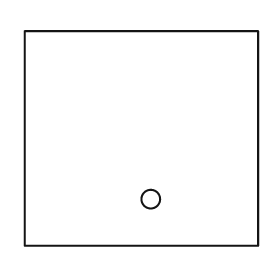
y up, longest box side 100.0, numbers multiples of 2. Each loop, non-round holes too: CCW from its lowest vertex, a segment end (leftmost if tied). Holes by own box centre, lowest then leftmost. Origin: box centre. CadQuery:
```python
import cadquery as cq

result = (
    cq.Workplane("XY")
    .moveTo(-50.0, -46.0)
    .lineTo(50.0, -46.0)
    .lineTo(50.0, 46.0)
    .lineTo(-50.0, 46.0)
    .close()
    .moveTo(4.0, -26.0)
    .circle(4.0)
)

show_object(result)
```